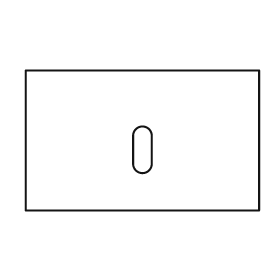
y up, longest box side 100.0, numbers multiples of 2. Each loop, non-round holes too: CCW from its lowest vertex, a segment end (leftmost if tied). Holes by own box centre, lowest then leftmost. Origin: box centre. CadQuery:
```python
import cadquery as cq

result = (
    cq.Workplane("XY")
    .moveTo(-50.0, -30.0)
    .lineTo(50.0, -30.0)
    .lineTo(50.0, 30.0)
    .lineTo(-50.0, 30.0)
    .close()
    .moveTo(-4.0, -10.0)
    .threePointArc((0.0, -14.0), (4.0, -10.0))
    .lineTo(4.0, 2.0)
    .threePointArc((0.0, 6.0), (-4.0, 2.0))
    .close()
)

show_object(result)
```